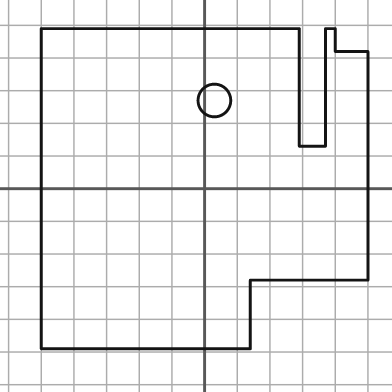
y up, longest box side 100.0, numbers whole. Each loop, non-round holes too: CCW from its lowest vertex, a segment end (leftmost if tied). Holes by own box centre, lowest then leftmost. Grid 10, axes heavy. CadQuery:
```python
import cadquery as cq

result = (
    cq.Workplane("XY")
    .moveTo(-50.0, -49.0)
    .lineTo(14.0, -49.0)
    .lineTo(14.0, -28.0)
    .lineTo(50.0, -28.0)
    .lineTo(50.0, 42.0)
    .lineTo(40.0, 42.0)
    .lineTo(40.0, 49.0)
    .lineTo(37.0, 49.0)
    .lineTo(37.0, 13.0)
    .lineTo(29.0, 13.0)
    .lineTo(29.0, 49.0)
    .lineTo(-50.0, 49.0)
    .close()
    .moveTo(3.0, 27.0)
    .circle(5.0)
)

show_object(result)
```